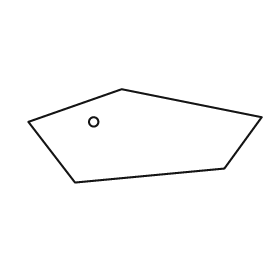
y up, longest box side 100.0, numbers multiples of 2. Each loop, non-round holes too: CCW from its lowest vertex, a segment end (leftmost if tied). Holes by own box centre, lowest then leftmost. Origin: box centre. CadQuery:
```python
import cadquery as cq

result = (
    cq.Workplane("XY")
    .moveTo(-30.0, -20.0)
    .lineTo(34.0, -14.0)
    .lineTo(50.0, 8.0)
    .lineTo(-10.0, 20.0)
    .lineTo(-50.0, 6.0)
    .close()
    .moveTo(-22.0, 6.0)
    .circle(2.0)
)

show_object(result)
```